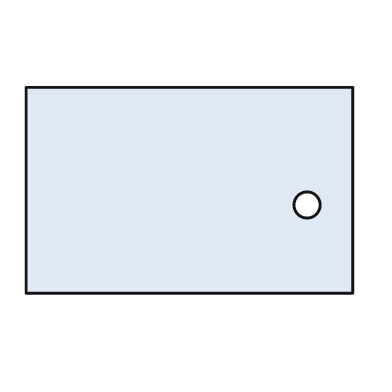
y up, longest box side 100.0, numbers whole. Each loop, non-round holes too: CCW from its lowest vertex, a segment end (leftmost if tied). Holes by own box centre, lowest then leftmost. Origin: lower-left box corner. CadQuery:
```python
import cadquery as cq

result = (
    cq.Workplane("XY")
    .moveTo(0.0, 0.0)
    .lineTo(100.0, 0.0)
    .lineTo(100.0, 63.0)
    .lineTo(0.0, 63.0)
    .close()
    .moveTo(86.0, 27.0)
    .circle(4.0)
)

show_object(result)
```